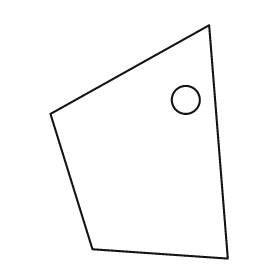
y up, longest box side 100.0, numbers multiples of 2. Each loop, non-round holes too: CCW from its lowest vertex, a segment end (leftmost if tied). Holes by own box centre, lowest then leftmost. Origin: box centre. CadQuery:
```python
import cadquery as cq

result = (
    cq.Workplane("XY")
    .moveTo(38.0, -50.0)
    .lineTo(30.0, 50.0)
    .lineTo(-38.0, 12.0)
    .lineTo(-20.0, -46.0)
    .close()
    .moveTo(20.0, 18.0)
    .circle(6.0)
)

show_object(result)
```